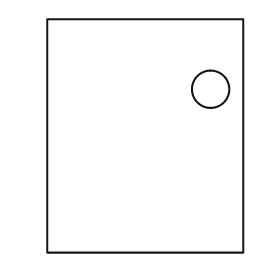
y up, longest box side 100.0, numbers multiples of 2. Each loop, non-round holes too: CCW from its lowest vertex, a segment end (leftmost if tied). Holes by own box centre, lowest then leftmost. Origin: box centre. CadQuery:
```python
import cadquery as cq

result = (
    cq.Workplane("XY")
    .moveTo(-42.0, -50.0)
    .lineTo(42.0, -50.0)
    .lineTo(42.0, 50.0)
    .lineTo(-42.0, 50.0)
    .close()
    .moveTo(28.0, 20.0)
    .circle(8.0)
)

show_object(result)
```